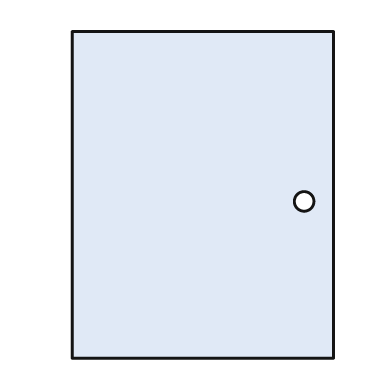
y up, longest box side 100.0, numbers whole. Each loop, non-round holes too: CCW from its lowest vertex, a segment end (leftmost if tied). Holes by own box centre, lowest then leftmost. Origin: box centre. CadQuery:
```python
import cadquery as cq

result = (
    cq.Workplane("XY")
    .moveTo(-40.0, -50.0)
    .lineTo(40.0, -50.0)
    .lineTo(40.0, 50.0)
    .lineTo(-40.0, 50.0)
    .close()
    .moveTo(31.0, -2.0)
    .circle(3.0)
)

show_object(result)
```